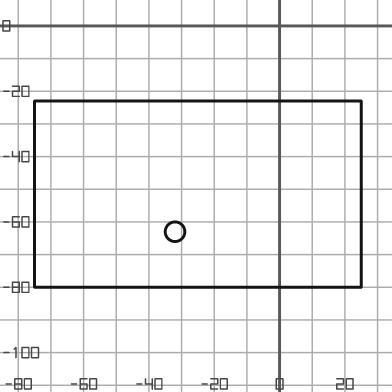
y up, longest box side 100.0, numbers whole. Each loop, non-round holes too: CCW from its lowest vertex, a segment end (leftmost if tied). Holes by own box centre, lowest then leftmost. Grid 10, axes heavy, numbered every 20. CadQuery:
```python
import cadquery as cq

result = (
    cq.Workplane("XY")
    .moveTo(-75.0, -80.0)
    .lineTo(25.0, -80.0)
    .lineTo(25.0, -23.0)
    .lineTo(-75.0, -23.0)
    .close()
    .moveTo(-32.0, -63.0)
    .circle(3.0)
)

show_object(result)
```